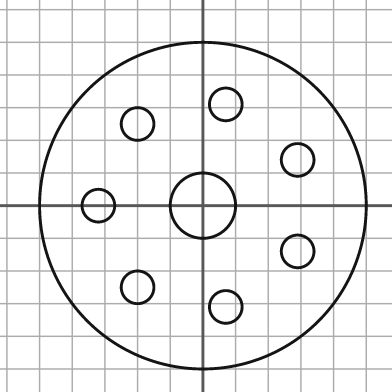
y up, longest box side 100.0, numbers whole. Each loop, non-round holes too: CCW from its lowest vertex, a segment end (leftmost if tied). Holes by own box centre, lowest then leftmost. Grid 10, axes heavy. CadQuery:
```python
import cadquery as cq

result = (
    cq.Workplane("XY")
    .moveTo(0.0, 0.0)
    .circle(50.0)
    .moveTo(7.0, -31.0)
    .circle(5.0)
    .moveTo(-20.0, -25.0)
    .circle(5.0)
    .moveTo(29.0, -14.0)
    .circle(5.0)
    .moveTo(-32.0, 0.0)
    .circle(5.0)
    .moveTo(0.0, 0.0)
    .circle(10.0)
    .moveTo(29.0, 14.0)
    .circle(5.0)
    .moveTo(-20.0, 25.0)
    .circle(5.0)
    .moveTo(7.0, 31.0)
    .circle(5.0)
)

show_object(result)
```